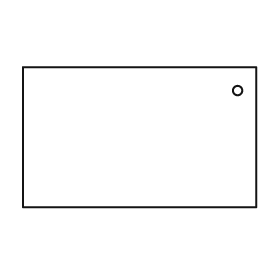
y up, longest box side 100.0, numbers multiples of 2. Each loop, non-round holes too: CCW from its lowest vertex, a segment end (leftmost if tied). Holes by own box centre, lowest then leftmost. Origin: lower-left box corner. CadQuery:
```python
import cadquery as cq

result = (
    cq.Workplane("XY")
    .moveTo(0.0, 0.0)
    .lineTo(100.0, 0.0)
    .lineTo(100.0, 60.0)
    .lineTo(0.0, 60.0)
    .close()
    .moveTo(92.0, 50.0)
    .circle(2.0)
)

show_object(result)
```